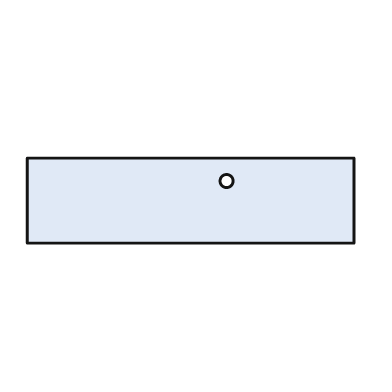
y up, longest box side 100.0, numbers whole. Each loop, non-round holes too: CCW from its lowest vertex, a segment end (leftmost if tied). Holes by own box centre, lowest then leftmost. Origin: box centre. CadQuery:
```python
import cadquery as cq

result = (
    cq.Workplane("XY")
    .moveTo(-50.0, -13.0)
    .lineTo(50.0, -13.0)
    .lineTo(50.0, 13.0)
    .lineTo(-50.0, 13.0)
    .close()
    .moveTo(11.0, 6.0)
    .circle(2.0)
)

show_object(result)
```